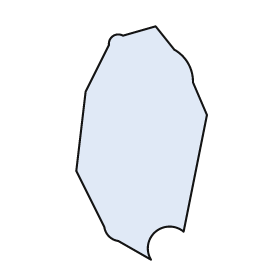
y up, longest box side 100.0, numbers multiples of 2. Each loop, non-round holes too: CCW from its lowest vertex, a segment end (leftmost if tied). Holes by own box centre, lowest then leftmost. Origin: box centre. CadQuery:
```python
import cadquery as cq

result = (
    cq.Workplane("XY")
    .moveTo(4.0, -50.0)
    .threePointArc((6.0, -38.0), (18.0, -38.0))
    .lineTo(28.0, 12.0)
    .lineTo(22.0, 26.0)
    .threePointArc((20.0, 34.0), (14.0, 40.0))
    .lineTo(6.0, 50.0)
    .lineTo(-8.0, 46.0)
    .threePointArc((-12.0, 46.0), (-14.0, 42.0))
    .lineTo(-24.0, 22.0)
    .lineTo(-28.0, -12.0)
    .lineTo(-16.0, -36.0)
    .threePointArc((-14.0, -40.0), (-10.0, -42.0))
    .close()
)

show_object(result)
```